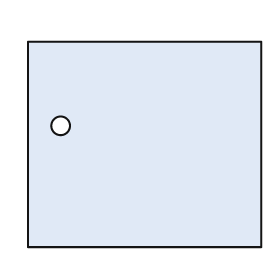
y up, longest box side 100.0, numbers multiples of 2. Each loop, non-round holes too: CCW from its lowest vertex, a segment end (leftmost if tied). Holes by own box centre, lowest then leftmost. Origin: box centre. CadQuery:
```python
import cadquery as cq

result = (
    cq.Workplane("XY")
    .moveTo(-50.0, -44.0)
    .lineTo(50.0, -44.0)
    .lineTo(50.0, 44.0)
    .lineTo(-50.0, 44.0)
    .close()
    .moveTo(-36.0, 8.0)
    .circle(4.0)
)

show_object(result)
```